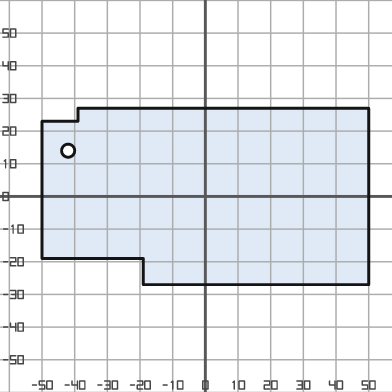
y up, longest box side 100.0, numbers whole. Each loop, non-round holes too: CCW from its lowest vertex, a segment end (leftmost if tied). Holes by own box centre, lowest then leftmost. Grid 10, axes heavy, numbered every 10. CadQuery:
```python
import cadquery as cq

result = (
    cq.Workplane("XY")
    .moveTo(-19.0, -27.0)
    .lineTo(50.0, -27.0)
    .lineTo(50.0, 27.0)
    .lineTo(-39.0, 27.0)
    .lineTo(-39.0, 23.0)
    .lineTo(-50.0, 23.0)
    .lineTo(-50.0, -19.0)
    .lineTo(-19.0, -19.0)
    .close()
    .moveTo(-42.0, 14.0)
    .circle(2.0)
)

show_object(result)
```